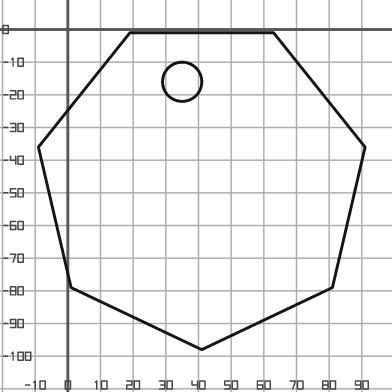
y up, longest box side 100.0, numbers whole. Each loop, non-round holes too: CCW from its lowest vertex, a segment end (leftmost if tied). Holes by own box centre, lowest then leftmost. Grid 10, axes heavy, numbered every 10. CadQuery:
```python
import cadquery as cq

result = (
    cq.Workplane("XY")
    .moveTo(41.0, -98.0)
    .lineTo(81.0, -79.0)
    .lineTo(91.0, -36.0)
    .lineTo(63.0, -1.0)
    .lineTo(19.0, -1.0)
    .lineTo(-9.0, -36.0)
    .lineTo(1.0, -79.0)
    .close()
    .moveTo(35.0, -16.0)
    .circle(6.0)
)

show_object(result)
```